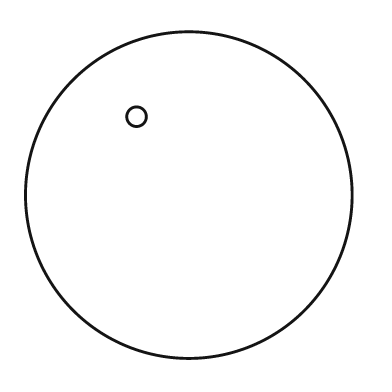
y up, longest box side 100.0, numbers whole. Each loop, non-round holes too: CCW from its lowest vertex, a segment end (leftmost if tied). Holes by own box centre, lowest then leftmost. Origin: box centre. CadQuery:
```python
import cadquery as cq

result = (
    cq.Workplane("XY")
    .moveTo(0.0, 0.0)
    .circle(50.0)
    .moveTo(-16.0, 24.0)
    .circle(3.0)
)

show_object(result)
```